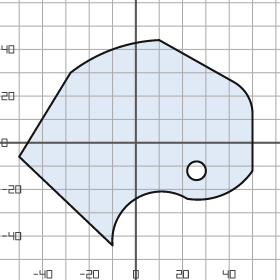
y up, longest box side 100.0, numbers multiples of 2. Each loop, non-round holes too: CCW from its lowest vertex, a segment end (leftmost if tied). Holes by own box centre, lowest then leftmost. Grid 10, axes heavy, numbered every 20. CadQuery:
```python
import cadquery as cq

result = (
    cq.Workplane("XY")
    .moveTo(-10.0, -44.0)
    .threePointArc((0.0, -24.0), (22.0, -24.0))
    .threePointArc((38.0, -22.0), (50.0, -12.0))
    .lineTo(50.0, 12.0)
    .threePointArc((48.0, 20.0), (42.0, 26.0))
    .lineTo(10.0, 44.0)
    .threePointArc((-10.0, 40.0), (-28.0, 30.0))
    .lineTo(-50.0, -6.0)
    .close()
    .moveTo(26.0, -12.0)
    .circle(4.0)
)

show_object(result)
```